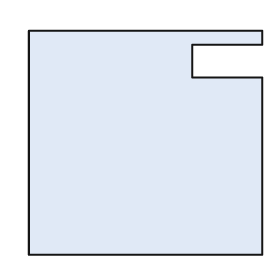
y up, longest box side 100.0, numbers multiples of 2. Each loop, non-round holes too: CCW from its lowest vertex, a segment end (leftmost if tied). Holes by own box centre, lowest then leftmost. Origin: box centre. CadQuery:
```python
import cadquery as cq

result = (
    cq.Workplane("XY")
    .moveTo(-50.0, -48.0)
    .lineTo(50.0, -48.0)
    .lineTo(50.0, 28.0)
    .lineTo(20.0, 28.0)
    .lineTo(20.0, 42.0)
    .lineTo(50.0, 42.0)
    .lineTo(50.0, 48.0)
    .lineTo(-50.0, 48.0)
    .close()
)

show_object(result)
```